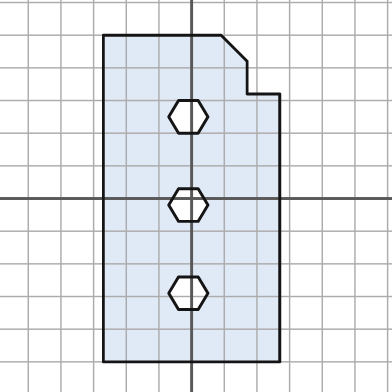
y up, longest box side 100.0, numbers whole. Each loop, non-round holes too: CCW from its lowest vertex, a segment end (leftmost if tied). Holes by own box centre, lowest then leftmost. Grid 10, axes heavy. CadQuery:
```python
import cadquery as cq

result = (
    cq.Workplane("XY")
    .moveTo(-27.0, -50.0)
    .lineTo(27.0, -50.0)
    .lineTo(27.0, 32.0)
    .lineTo(17.0, 32.0)
    .lineTo(17.0, 42.0)
    .lineTo(9.0, 50.0)
    .lineTo(-27.0, 50.0)
    .close()
    .moveTo(-4.0, -34.0)
    .lineTo(2.0, -34.0)
    .lineTo(5.0, -29.0)
    .lineTo(2.0, -24.0)
    .lineTo(-4.0, -24.0)
    .lineTo(-7.0, -29.0)
    .close()
    .moveTo(-4.0, -7.0)
    .lineTo(2.0, -7.0)
    .lineTo(5.0, -2.0)
    .lineTo(2.0, 3.0)
    .lineTo(-4.0, 3.0)
    .lineTo(-7.0, -2.0)
    .close()
    .moveTo(-4.0, 20.0)
    .lineTo(2.0, 20.0)
    .lineTo(5.0, 25.0)
    .lineTo(2.0, 30.0)
    .lineTo(-4.0, 30.0)
    .lineTo(-7.0, 25.0)
    .close()
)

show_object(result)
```